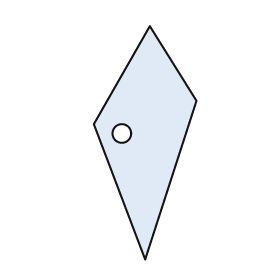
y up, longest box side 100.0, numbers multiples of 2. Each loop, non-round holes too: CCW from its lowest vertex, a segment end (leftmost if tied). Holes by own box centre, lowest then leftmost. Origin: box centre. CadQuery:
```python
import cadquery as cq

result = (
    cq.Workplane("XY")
    .moveTo(0.0, -50.0)
    .lineTo(22.0, 18.0)
    .lineTo(2.0, 50.0)
    .lineTo(-22.0, 8.0)
    .close()
    .moveTo(-10.0, 4.0)
    .circle(4.0)
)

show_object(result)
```